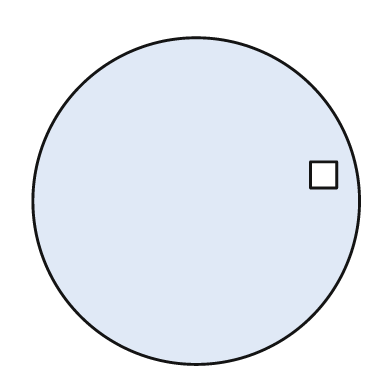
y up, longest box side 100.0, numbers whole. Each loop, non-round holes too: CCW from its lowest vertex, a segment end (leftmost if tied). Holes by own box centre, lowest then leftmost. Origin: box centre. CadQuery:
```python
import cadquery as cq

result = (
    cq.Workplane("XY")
    .moveTo(0.0, 0.0)
    .circle(50.0)
    .moveTo(35.0, 4.0)
    .lineTo(43.0, 4.0)
    .lineTo(43.0, 12.0)
    .lineTo(35.0, 12.0)
    .close()
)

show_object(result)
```